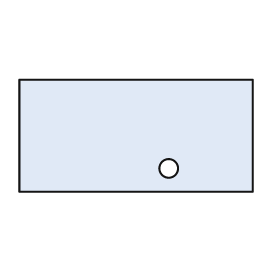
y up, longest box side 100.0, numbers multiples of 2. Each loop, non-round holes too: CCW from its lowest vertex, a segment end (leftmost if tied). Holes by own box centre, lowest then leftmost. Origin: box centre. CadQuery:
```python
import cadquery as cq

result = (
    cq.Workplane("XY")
    .moveTo(-50.0, -24.0)
    .lineTo(50.0, -24.0)
    .lineTo(50.0, 24.0)
    .lineTo(-50.0, 24.0)
    .close()
    .moveTo(14.0, -14.0)
    .circle(4.0)
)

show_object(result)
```